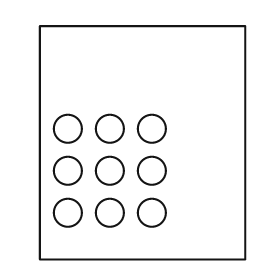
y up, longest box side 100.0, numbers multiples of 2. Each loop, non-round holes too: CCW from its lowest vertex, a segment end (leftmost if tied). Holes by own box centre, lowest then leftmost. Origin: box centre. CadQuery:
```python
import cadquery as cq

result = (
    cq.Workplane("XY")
    .moveTo(-44.0, -50.0)
    .lineTo(44.0, -50.0)
    .lineTo(44.0, 50.0)
    .lineTo(-44.0, 50.0)
    .close()
    .moveTo(-32.0, -30.0)
    .circle(6.0)
    .moveTo(-14.0, -30.0)
    .circle(6.0)
    .moveTo(4.0, -30.0)
    .circle(6.0)
    .moveTo(-32.0, -12.0)
    .circle(6.0)
    .moveTo(-14.0, -12.0)
    .circle(6.0)
    .moveTo(4.0, -12.0)
    .circle(6.0)
    .moveTo(-32.0, 6.0)
    .circle(6.0)
    .moveTo(-14.0, 6.0)
    .circle(6.0)
    .moveTo(4.0, 6.0)
    .circle(6.0)
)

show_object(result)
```